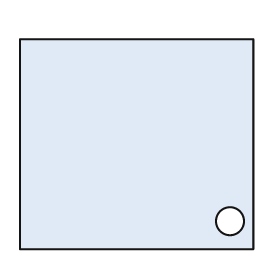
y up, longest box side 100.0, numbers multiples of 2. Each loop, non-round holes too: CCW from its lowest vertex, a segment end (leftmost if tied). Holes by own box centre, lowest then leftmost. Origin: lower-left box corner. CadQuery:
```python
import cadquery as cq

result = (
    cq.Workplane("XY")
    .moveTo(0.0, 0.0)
    .lineTo(100.0, 0.0)
    .lineTo(100.0, 90.0)
    .lineTo(0.0, 90.0)
    .close()
    .moveTo(90.0, 12.0)
    .circle(6.0)
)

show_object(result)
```